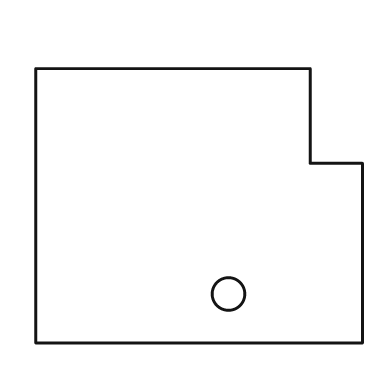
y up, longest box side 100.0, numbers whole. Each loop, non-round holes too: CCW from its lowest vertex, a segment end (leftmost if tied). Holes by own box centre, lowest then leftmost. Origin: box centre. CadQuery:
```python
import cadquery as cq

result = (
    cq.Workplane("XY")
    .moveTo(-50.0, -42.0)
    .lineTo(50.0, -42.0)
    .lineTo(50.0, 13.0)
    .lineTo(34.0, 13.0)
    .lineTo(34.0, 42.0)
    .lineTo(-50.0, 42.0)
    .close()
    .moveTo(9.0, -27.0)
    .circle(5.0)
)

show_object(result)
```